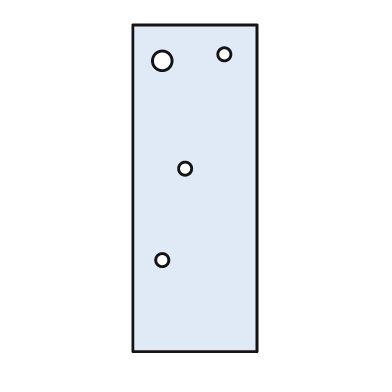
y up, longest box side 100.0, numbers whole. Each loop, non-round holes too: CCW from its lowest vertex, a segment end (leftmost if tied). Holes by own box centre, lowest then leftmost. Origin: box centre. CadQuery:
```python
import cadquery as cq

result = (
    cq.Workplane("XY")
    .moveTo(-19.0, -50.0)
    .lineTo(19.0, -50.0)
    .lineTo(19.0, 50.0)
    .lineTo(-19.0, 50.0)
    .close()
    .moveTo(-10.0, -22.0)
    .circle(2.0)
    .moveTo(-3.0, 6.0)
    .circle(2.0)
    .moveTo(-10.0, 39.0)
    .circle(3.0)
    .moveTo(9.0, 41.0)
    .circle(2.0)
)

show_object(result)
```